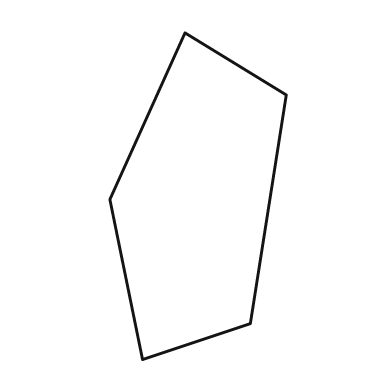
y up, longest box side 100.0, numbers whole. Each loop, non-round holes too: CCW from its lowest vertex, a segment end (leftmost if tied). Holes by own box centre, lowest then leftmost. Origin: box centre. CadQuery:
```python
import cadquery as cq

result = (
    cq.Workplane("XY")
    .moveTo(-17.0, -50.0)
    .lineTo(16.0, -39.0)
    .lineTo(27.0, 31.0)
    .lineTo(-4.0, 50.0)
    .lineTo(-27.0, -1.0)
    .close()
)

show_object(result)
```